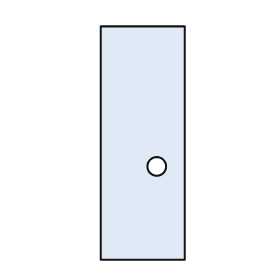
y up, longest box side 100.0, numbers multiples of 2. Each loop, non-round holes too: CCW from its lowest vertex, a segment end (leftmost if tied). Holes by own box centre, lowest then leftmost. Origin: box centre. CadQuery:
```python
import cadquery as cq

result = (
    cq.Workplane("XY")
    .moveTo(-18.0, -50.0)
    .lineTo(18.0, -50.0)
    .lineTo(18.0, 50.0)
    .lineTo(-18.0, 50.0)
    .close()
    .moveTo(6.0, -10.0)
    .circle(4.0)
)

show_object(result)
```